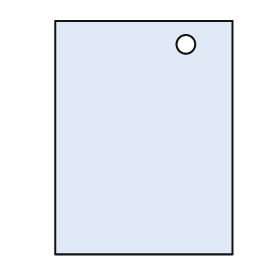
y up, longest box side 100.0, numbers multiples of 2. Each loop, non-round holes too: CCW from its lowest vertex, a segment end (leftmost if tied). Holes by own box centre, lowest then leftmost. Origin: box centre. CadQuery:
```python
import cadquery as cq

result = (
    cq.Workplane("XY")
    .moveTo(-38.0, -50.0)
    .lineTo(38.0, -50.0)
    .lineTo(38.0, 50.0)
    .lineTo(-38.0, 50.0)
    .close()
    .moveTo(18.0, 40.0)
    .circle(4.0)
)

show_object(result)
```